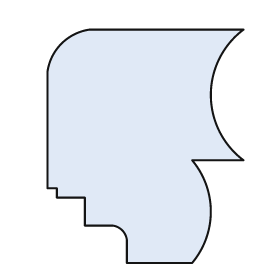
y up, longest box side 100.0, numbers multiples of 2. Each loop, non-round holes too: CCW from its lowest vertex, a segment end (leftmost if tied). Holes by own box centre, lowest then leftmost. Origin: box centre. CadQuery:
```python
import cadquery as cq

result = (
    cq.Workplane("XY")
    .moveTo(-8.0, -50.0)
    .lineTo(20.0, -50.0)
    .threePointArc((28.0, -28.0), (20.0, -6.0))
    .lineTo(42.0, -6.0)
    .threePointArc((28.0, 22.0), (42.0, 50.0))
    .lineTo(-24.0, 50.0)
    .threePointArc((-36.0, 44.0), (-42.0, 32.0))
    .lineTo(-42.0, -18.0)
    .lineTo(-38.0, -18.0)
    .lineTo(-38.0, -22.0)
    .lineTo(-26.0, -22.0)
    .lineTo(-26.0, -34.0)
    .lineTo(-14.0, -34.0)
    .threePointArc((-10.0, -36.0), (-8.0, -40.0))
    .close()
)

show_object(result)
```